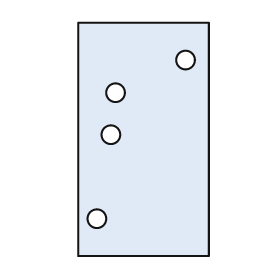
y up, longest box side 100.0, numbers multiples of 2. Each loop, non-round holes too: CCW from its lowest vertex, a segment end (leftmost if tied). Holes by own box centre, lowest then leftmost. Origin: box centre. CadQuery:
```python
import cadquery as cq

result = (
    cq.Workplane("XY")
    .moveTo(-28.0, -50.0)
    .lineTo(28.0, -50.0)
    .lineTo(28.0, 50.0)
    .lineTo(-28.0, 50.0)
    .close()
    .moveTo(-20.0, -34.0)
    .circle(4.0)
    .moveTo(-14.0, 2.0)
    .circle(4.0)
    .moveTo(-12.0, 20.0)
    .circle(4.0)
    .moveTo(18.0, 34.0)
    .circle(4.0)
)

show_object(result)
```